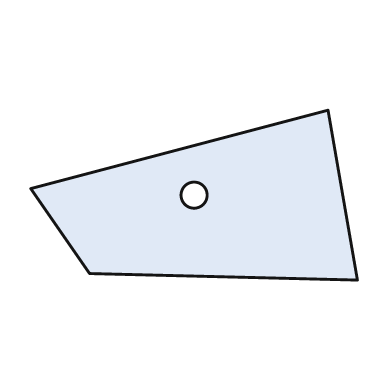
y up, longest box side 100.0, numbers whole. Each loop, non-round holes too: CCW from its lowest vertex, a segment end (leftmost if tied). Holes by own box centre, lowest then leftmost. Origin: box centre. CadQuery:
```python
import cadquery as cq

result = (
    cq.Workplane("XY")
    .moveTo(50.0, -26.0)
    .lineTo(41.0, 26.0)
    .lineTo(-50.0, 2.0)
    .lineTo(-32.0, -24.0)
    .close()
    .moveTo(0.0, 0.0)
    .circle(4.0)
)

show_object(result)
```